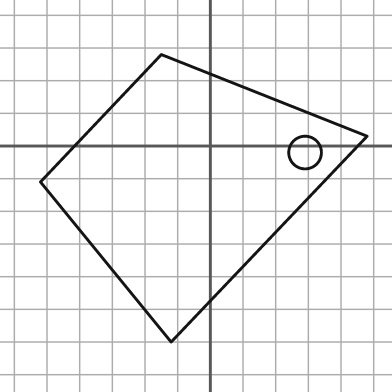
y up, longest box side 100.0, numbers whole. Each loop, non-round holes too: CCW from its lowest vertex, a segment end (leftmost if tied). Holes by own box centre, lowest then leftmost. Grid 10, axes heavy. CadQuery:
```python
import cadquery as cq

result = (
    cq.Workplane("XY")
    .moveTo(-12.0, -60.0)
    .lineTo(48.0, 3.0)
    .lineTo(-15.0, 28.0)
    .lineTo(-52.0, -11.0)
    .close()
    .moveTo(29.0, -2.0)
    .circle(5.0)
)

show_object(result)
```